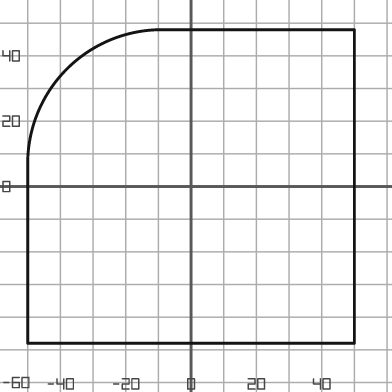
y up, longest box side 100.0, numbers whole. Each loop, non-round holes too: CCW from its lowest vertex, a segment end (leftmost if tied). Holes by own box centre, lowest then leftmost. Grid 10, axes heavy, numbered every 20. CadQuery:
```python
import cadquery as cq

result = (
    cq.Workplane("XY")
    .moveTo(-50.0, -48.0)
    .lineTo(50.0, -48.0)
    .lineTo(50.0, 48.0)
    .lineTo(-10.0, 48.0)
    .threePointArc((-38.0, 36.0), (-50.0, 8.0))
    .close()
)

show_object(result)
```